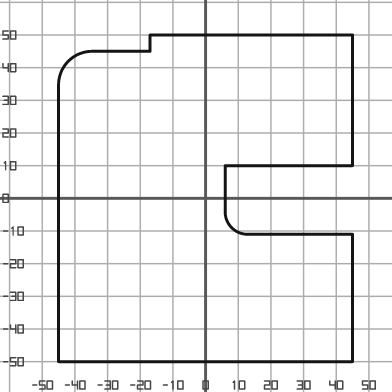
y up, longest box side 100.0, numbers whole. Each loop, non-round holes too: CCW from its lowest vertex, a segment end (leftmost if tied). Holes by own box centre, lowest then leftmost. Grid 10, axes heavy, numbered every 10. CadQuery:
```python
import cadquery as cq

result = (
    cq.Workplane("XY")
    .moveTo(-45.0, -50.0)
    .lineTo(45.0, -50.0)
    .lineTo(45.0, -11.0)
    .lineTo(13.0, -11.0)
    .threePointArc((8.0, -9.0), (6.0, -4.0))
    .lineTo(6.0, 10.0)
    .lineTo(45.0, 10.0)
    .lineTo(45.0, 50.0)
    .lineTo(-17.0, 50.0)
    .lineTo(-17.0, 45.0)
    .lineTo(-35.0, 45.0)
    .threePointArc((-42.0, 42.0), (-45.0, 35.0))
    .close()
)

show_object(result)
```